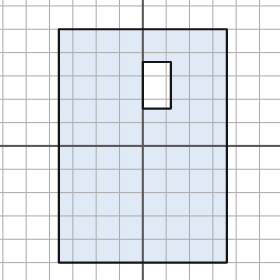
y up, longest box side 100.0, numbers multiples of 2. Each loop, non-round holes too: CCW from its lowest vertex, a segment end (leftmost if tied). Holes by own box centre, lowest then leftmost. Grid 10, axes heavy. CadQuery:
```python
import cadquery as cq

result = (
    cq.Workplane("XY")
    .moveTo(-36.0, -50.0)
    .lineTo(36.0, -50.0)
    .lineTo(36.0, 50.0)
    .lineTo(-36.0, 50.0)
    .close()
    .moveTo(0.0, 16.0)
    .lineTo(12.0, 16.0)
    .lineTo(12.0, 36.0)
    .lineTo(0.0, 36.0)
    .close()
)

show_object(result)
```